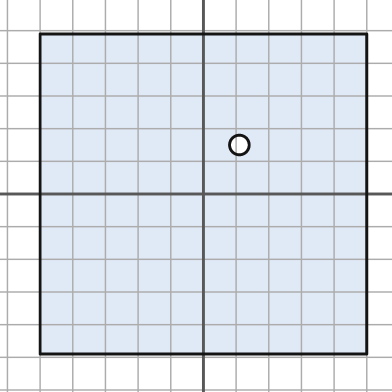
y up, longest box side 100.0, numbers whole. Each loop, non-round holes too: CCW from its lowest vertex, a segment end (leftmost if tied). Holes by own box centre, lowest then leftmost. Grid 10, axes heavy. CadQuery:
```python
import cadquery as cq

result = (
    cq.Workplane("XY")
    .moveTo(-50.0, -49.0)
    .lineTo(50.0, -49.0)
    .lineTo(50.0, 49.0)
    .lineTo(-50.0, 49.0)
    .close()
    .moveTo(11.0, 15.0)
    .circle(3.0)
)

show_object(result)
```